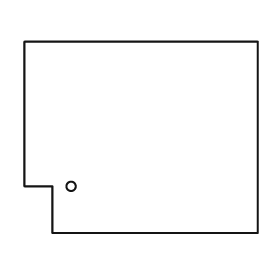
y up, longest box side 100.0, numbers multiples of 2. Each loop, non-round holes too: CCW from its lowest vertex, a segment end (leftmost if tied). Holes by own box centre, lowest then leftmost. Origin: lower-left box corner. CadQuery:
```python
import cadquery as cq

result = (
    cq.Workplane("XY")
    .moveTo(12.0, 0.0)
    .lineTo(100.0, 0.0)
    .lineTo(100.0, 82.0)
    .lineTo(0.0, 82.0)
    .lineTo(0.0, 20.0)
    .lineTo(12.0, 20.0)
    .close()
    .moveTo(20.0, 20.0)
    .circle(2.0)
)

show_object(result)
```